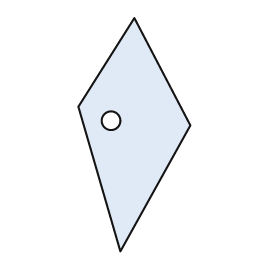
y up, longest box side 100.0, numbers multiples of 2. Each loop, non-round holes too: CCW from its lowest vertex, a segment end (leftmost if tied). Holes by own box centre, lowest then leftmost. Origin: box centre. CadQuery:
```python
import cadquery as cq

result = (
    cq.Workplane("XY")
    .moveTo(-6.0, -50.0)
    .lineTo(24.0, 4.0)
    .lineTo(0.0, 50.0)
    .lineTo(-24.0, 12.0)
    .close()
    .moveTo(-10.0, 6.0)
    .circle(4.0)
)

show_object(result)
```